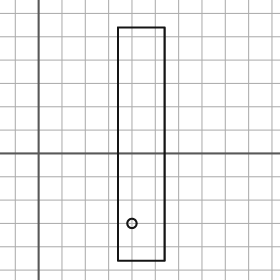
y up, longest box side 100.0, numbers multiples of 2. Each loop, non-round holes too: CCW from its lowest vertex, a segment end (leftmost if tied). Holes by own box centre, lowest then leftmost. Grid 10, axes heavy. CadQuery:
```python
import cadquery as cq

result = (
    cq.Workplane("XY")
    .moveTo(34.0, -46.0)
    .lineTo(54.0, -46.0)
    .lineTo(54.0, 54.0)
    .lineTo(34.0, 54.0)
    .close()
    .moveTo(40.0, -30.0)
    .circle(2.0)
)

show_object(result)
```